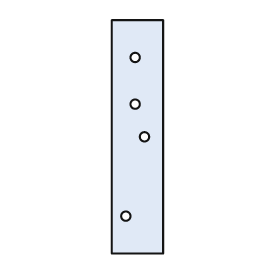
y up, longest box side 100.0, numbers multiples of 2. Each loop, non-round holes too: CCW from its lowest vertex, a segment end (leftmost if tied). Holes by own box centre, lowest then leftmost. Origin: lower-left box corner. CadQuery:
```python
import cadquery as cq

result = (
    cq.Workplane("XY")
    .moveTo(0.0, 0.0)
    .lineTo(22.0, 0.0)
    .lineTo(22.0, 100.0)
    .lineTo(0.0, 100.0)
    .close()
    .moveTo(6.0, 16.0)
    .circle(2.0)
    .moveTo(14.0, 50.0)
    .circle(2.0)
    .moveTo(10.0, 64.0)
    .circle(2.0)
    .moveTo(10.0, 84.0)
    .circle(2.0)
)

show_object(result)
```